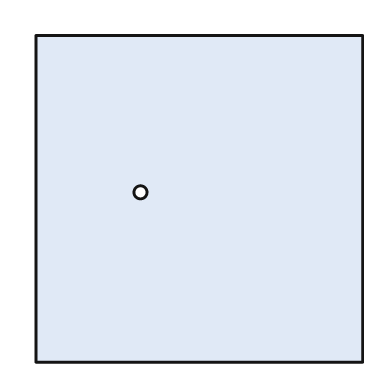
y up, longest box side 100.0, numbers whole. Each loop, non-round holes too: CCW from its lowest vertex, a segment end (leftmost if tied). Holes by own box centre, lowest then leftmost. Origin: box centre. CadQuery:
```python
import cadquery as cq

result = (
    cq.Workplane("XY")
    .moveTo(-50.0, -50.0)
    .lineTo(50.0, -50.0)
    .lineTo(50.0, 50.0)
    .lineTo(-50.0, 50.0)
    .close()
    .moveTo(-18.0, 2.0)
    .circle(2.0)
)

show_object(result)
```